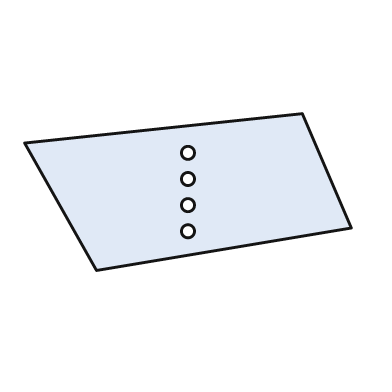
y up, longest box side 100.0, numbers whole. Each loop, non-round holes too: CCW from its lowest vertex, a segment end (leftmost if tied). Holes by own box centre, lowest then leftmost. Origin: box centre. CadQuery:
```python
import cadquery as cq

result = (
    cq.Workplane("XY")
    .moveTo(-28.0, -24.0)
    .lineTo(50.0, -11.0)
    .lineTo(35.0, 24.0)
    .lineTo(-50.0, 15.0)
    .close()
    .moveTo(0.0, -12.0)
    .circle(2.0)
    .moveTo(0.0, -4.0)
    .circle(2.0)
    .moveTo(0.0, 4.0)
    .circle(2.0)
    .moveTo(0.0, 12.0)
    .circle(2.0)
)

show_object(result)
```